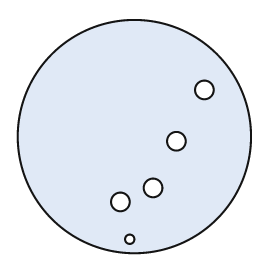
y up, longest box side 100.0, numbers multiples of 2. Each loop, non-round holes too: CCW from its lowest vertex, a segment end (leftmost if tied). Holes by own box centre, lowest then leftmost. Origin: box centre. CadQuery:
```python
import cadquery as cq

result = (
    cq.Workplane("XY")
    .moveTo(0.0, 0.0)
    .circle(50.0)
    .moveTo(-2.0, -44.0)
    .circle(2.0)
    .moveTo(-6.0, -28.0)
    .circle(4.0)
    .moveTo(8.0, -22.0)
    .circle(4.0)
    .moveTo(18.0, -2.0)
    .circle(4.0)
    .moveTo(30.0, 20.0)
    .circle(4.0)
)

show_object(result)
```